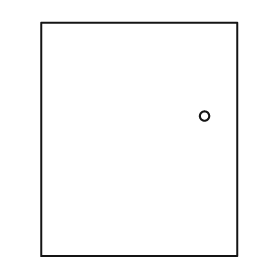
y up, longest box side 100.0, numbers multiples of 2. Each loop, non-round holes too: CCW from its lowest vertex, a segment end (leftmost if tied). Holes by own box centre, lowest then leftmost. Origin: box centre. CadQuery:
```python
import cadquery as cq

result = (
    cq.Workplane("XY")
    .moveTo(-42.0, -50.0)
    .lineTo(42.0, -50.0)
    .lineTo(42.0, 50.0)
    .lineTo(-42.0, 50.0)
    .close()
    .moveTo(28.0, 10.0)
    .circle(2.0)
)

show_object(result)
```